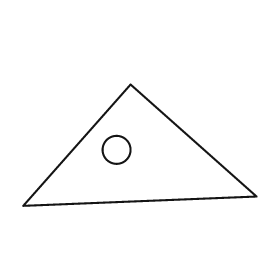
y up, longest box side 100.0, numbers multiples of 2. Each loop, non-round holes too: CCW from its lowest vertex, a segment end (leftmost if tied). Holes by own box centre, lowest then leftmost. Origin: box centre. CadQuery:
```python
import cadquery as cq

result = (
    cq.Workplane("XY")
    .moveTo(-50.0, -26.0)
    .lineTo(50.0, -22.0)
    .lineTo(-4.0, 26.0)
    .close()
    .moveTo(-10.0, -2.0)
    .circle(6.0)
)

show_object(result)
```